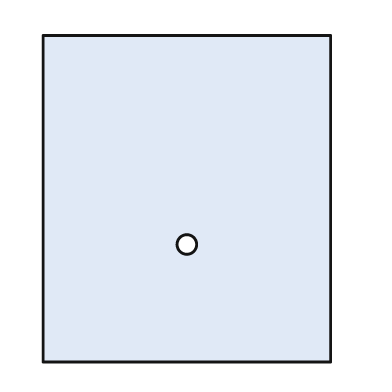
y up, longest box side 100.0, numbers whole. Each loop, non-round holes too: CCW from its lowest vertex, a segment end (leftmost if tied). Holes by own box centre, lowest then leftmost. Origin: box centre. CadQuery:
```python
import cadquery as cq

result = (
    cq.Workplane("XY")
    .moveTo(-44.0, -50.0)
    .lineTo(44.0, -50.0)
    .lineTo(44.0, 50.0)
    .lineTo(-44.0, 50.0)
    .close()
    .moveTo(0.0, -14.0)
    .circle(3.0)
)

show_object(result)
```